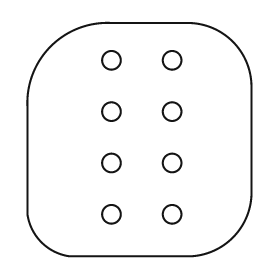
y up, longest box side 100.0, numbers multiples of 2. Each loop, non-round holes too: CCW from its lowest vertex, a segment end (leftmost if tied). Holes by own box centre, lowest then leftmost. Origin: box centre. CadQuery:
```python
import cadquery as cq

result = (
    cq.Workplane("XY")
    .moveTo(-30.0, -50.0)
    .lineTo(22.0, -50.0)
    .threePointArc((40.0, -42.0), (48.0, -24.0))
    .lineTo(48.0, 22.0)
    .threePointArc((40.0, 42.0), (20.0, 50.0))
    .lineTo(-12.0, 50.0)
    .threePointArc((-38.0, 40.0), (-48.0, 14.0))
    .lineTo(-48.0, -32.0)
    .threePointArc((-42.0, -44.0), (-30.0, -50.0))
    .close()
    .moveTo(-12.0, -32.0)
    .circle(4.0)
    .moveTo(14.0, -32.0)
    .circle(4.0)
    .moveTo(-12.0, -10.0)
    .circle(4.0)
    .moveTo(14.0, -10.0)
    .circle(4.0)
    .moveTo(-12.0, 12.0)
    .circle(4.0)
    .moveTo(14.0, 12.0)
    .circle(4.0)
    .moveTo(-12.0, 34.0)
    .circle(4.0)
    .moveTo(14.0, 34.0)
    .circle(4.0)
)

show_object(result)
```